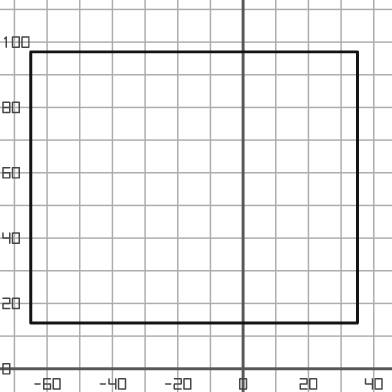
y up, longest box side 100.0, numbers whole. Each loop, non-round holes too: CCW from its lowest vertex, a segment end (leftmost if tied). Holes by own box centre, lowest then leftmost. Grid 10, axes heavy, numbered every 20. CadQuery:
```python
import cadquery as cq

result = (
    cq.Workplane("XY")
    .moveTo(-65.0, 14.0)
    .lineTo(35.0, 14.0)
    .lineTo(35.0, 97.0)
    .lineTo(-65.0, 97.0)
    .close()
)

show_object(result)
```